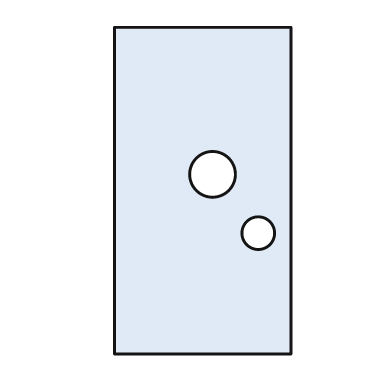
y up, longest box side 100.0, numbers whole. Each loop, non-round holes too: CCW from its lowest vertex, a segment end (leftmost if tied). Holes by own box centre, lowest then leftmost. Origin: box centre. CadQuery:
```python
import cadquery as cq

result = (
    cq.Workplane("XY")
    .moveTo(-27.0, -50.0)
    .lineTo(27.0, -50.0)
    .lineTo(27.0, 50.0)
    .lineTo(-27.0, 50.0)
    .close()
    .moveTo(17.0, -13.0)
    .circle(5.0)
    .moveTo(3.0, 5.0)
    .circle(7.0)
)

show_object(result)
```